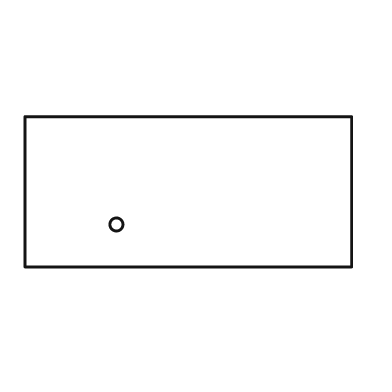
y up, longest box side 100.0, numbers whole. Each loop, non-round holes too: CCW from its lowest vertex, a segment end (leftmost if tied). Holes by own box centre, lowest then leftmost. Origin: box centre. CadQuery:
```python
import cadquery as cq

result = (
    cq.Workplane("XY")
    .moveTo(-50.0, -23.0)
    .lineTo(50.0, -23.0)
    .lineTo(50.0, 23.0)
    .lineTo(-50.0, 23.0)
    .close()
    .moveTo(-22.0, -10.0)
    .circle(2.0)
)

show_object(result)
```